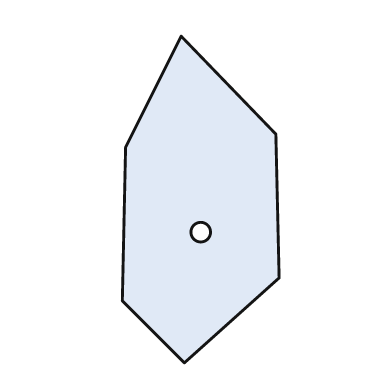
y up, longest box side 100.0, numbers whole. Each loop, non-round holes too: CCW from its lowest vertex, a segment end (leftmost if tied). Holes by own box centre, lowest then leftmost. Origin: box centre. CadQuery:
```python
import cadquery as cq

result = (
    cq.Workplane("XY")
    .moveTo(-5.0, -50.0)
    .lineTo(24.0, -24.0)
    .lineTo(23.0, 20.0)
    .lineTo(-6.0, 50.0)
    .lineTo(-23.0, 16.0)
    .lineTo(-24.0, -31.0)
    .close()
    .moveTo(0.0, -10.0)
    .circle(3.0)
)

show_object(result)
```